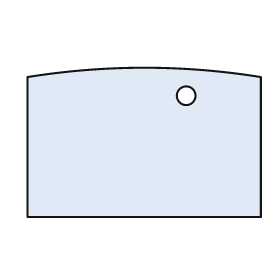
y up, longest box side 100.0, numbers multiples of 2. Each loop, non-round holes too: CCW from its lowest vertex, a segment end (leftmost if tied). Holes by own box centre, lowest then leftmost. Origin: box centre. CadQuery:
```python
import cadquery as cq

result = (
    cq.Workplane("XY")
    .moveTo(-50.0, -32.0)
    .lineTo(50.0, -32.0)
    .lineTo(50.0, 28.0)
    .threePointArc((0.0, 32.0), (-50.0, 28.0))
    .close()
    .moveTo(18.0, 20.0)
    .circle(4.0)
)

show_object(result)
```